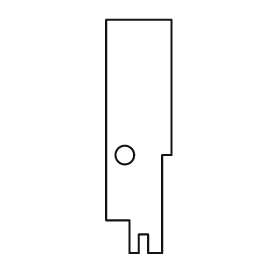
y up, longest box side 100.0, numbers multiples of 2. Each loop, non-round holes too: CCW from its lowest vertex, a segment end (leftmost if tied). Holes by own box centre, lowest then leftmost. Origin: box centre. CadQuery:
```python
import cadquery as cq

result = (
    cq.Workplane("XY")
    .moveTo(-4.0, -50.0)
    .lineTo(0.0, -50.0)
    .lineTo(0.0, -42.0)
    .lineTo(4.0, -42.0)
    .lineTo(4.0, -50.0)
    .lineTo(10.0, -50.0)
    .lineTo(10.0, -8.0)
    .lineTo(14.0, -8.0)
    .lineTo(14.0, 50.0)
    .lineTo(-14.0, 50.0)
    .lineTo(-14.0, -36.0)
    .lineTo(-4.0, -36.0)
    .close()
    .moveTo(-6.0, -8.0)
    .circle(4.0)
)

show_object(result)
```